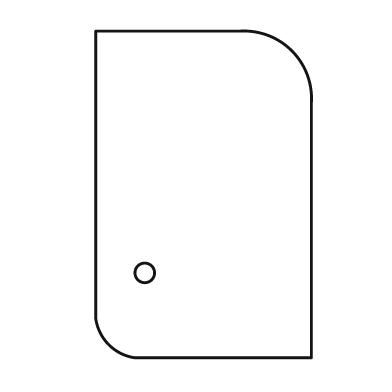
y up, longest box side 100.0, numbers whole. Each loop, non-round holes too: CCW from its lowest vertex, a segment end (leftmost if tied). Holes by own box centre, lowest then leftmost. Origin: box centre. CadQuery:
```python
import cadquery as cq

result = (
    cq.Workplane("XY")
    .moveTo(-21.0, -50.0)
    .lineTo(33.0, -50.0)
    .lineTo(33.0, 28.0)
    .threePointArc((27.0, 44.0), (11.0, 50.0))
    .lineTo(-33.0, 50.0)
    .lineTo(-33.0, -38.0)
    .threePointArc((-29.0, -46.0), (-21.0, -50.0))
    .close()
    .moveTo(-18.0, -24.0)
    .circle(3.0)
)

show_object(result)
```